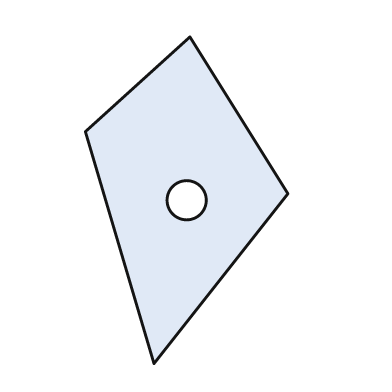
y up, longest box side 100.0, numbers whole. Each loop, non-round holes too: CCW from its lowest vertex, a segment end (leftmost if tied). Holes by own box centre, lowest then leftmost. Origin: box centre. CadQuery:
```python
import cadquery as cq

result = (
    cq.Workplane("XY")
    .moveTo(-10.0, -50.0)
    .lineTo(31.0, 2.0)
    .lineTo(1.0, 50.0)
    .lineTo(-31.0, 21.0)
    .close()
    .moveTo(0.0, 0.0)
    .circle(6.0)
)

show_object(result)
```